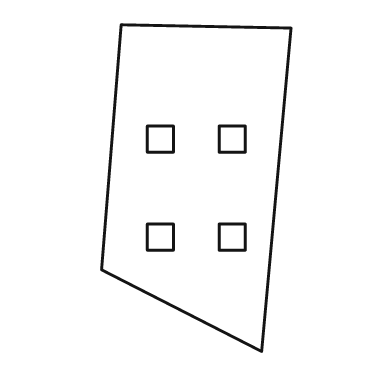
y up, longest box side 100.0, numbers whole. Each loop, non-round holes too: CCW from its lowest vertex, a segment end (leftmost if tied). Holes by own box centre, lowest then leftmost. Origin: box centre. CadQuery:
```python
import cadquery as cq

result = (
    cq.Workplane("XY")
    .moveTo(20.0, -50.0)
    .lineTo(29.0, 49.0)
    .lineTo(-23.0, 50.0)
    .lineTo(-29.0, -25.0)
    .close()
    .moveTo(-15.0, -19.0)
    .lineTo(-7.0, -19.0)
    .lineTo(-7.0, -11.0)
    .lineTo(-15.0, -11.0)
    .close()
    .moveTo(7.0, -19.0)
    .lineTo(15.0, -19.0)
    .lineTo(15.0, -11.0)
    .lineTo(7.0, -11.0)
    .close()
    .moveTo(-15.0, 11.0)
    .lineTo(-7.0, 11.0)
    .lineTo(-7.0, 19.0)
    .lineTo(-15.0, 19.0)
    .close()
    .moveTo(7.0, 11.0)
    .lineTo(15.0, 11.0)
    .lineTo(15.0, 19.0)
    .lineTo(7.0, 19.0)
    .close()
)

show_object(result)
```